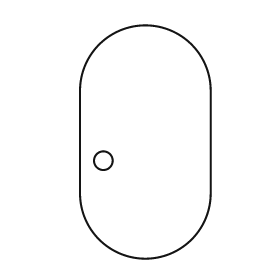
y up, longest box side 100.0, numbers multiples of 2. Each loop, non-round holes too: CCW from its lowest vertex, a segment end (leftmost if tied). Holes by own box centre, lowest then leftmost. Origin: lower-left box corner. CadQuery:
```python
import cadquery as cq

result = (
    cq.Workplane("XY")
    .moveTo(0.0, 28.0)
    .threePointArc((28.0, 0.0), (56.0, 28.0))
    .lineTo(56.0, 72.0)
    .threePointArc((28.0, 100.0), (0.0, 72.0))
    .close()
    .moveTo(10.0, 42.0)
    .circle(4.0)
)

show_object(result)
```